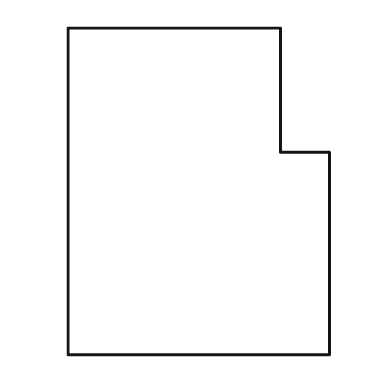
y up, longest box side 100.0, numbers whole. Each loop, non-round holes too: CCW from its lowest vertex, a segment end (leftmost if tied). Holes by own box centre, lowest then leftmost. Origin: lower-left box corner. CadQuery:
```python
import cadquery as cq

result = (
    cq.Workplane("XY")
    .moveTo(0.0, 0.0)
    .lineTo(80.0, 0.0)
    .lineTo(80.0, 62.0)
    .lineTo(65.0, 62.0)
    .lineTo(65.0, 100.0)
    .lineTo(0.0, 100.0)
    .close()
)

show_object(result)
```